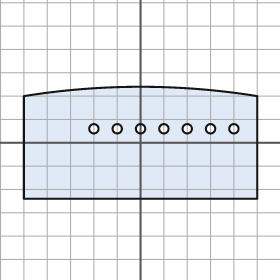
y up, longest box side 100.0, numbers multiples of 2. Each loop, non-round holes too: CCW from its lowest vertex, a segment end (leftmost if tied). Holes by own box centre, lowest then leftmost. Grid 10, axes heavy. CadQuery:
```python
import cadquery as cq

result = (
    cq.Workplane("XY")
    .moveTo(-50.0, -24.0)
    .lineTo(50.0, -24.0)
    .lineTo(50.0, 20.0)
    .threePointArc((0.0, 24.0), (-50.0, 20.0))
    .close()
    .moveTo(-20.0, 6.0)
    .circle(2.0)
    .moveTo(-10.0, 6.0)
    .circle(2.0)
    .moveTo(0.0, 6.0)
    .circle(2.0)
    .moveTo(10.0, 6.0)
    .circle(2.0)
    .moveTo(20.0, 6.0)
    .circle(2.0)
    .moveTo(30.0, 6.0)
    .circle(2.0)
    .moveTo(40.0, 6.0)
    .circle(2.0)
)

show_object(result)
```